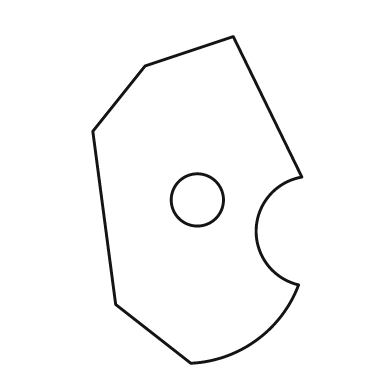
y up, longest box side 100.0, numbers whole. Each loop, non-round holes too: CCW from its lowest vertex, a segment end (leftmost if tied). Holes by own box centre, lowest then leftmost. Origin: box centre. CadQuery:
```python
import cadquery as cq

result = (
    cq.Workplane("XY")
    .moveTo(-2.0, -50.0)
    .threePointArc((18.0, -43.0), (31.0, -26.0))
    .threePointArc((18.0, -9.0), (32.0, 7.0))
    .lineTo(11.0, 50.0)
    .lineTo(-16.0, 41.0)
    .lineTo(-32.0, 21.0)
    .lineTo(-25.0, -32.0)
    .close()
    .moveTo(0.0, 0.0)
    .circle(8.0)
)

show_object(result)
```